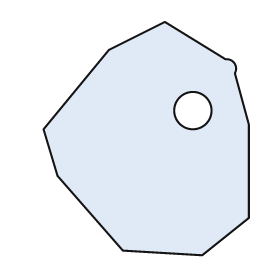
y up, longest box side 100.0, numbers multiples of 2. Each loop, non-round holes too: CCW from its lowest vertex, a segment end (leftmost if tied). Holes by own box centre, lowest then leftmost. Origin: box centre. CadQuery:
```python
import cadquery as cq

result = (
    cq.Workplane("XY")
    .moveTo(24.0, -50.0)
    .lineTo(44.0, -34.0)
    .lineTo(44.0, 6.0)
    .lineTo(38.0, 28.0)
    .threePointArc((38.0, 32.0), (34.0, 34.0))
    .lineTo(8.0, 50.0)
    .lineTo(-16.0, 38.0)
    .lineTo(-44.0, 4.0)
    .lineTo(-38.0, -16.0)
    .lineTo(-10.0, -48.0)
    .close()
    .moveTo(20.0, 12.0)
    .circle(8.0)
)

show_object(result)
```